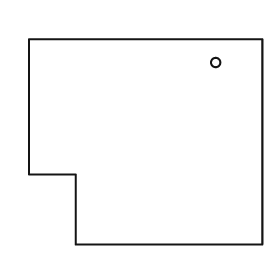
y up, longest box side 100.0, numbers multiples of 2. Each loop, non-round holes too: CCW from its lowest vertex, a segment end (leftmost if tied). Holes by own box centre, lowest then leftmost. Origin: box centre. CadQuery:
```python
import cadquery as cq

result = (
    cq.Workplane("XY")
    .moveTo(-30.0, -44.0)
    .lineTo(50.0, -44.0)
    .lineTo(50.0, 44.0)
    .lineTo(-50.0, 44.0)
    .lineTo(-50.0, -14.0)
    .lineTo(-30.0, -14.0)
    .close()
    .moveTo(30.0, 34.0)
    .circle(2.0)
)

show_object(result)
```